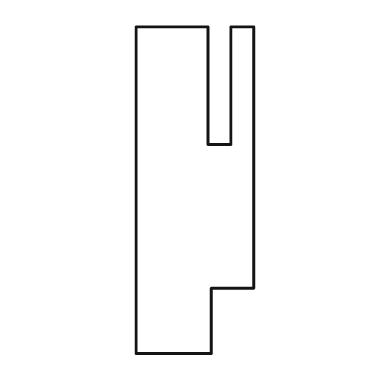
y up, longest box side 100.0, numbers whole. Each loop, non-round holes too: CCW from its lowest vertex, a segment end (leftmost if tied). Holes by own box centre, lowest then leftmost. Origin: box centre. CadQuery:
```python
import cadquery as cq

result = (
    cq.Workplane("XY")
    .moveTo(-18.0, -50.0)
    .lineTo(5.0, -50.0)
    .lineTo(5.0, -30.0)
    .lineTo(18.0, -30.0)
    .lineTo(18.0, 50.0)
    .lineTo(11.0, 50.0)
    .lineTo(11.0, 14.0)
    .lineTo(4.0, 14.0)
    .lineTo(4.0, 50.0)
    .lineTo(-18.0, 50.0)
    .close()
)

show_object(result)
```